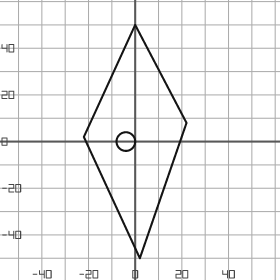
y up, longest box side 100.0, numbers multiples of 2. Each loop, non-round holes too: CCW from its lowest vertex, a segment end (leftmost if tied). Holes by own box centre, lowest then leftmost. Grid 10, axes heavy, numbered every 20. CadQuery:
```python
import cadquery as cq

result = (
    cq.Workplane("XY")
    .moveTo(2.0, -50.0)
    .lineTo(22.0, 8.0)
    .lineTo(0.0, 50.0)
    .lineTo(-22.0, 2.0)
    .close()
    .moveTo(-4.0, 0.0)
    .circle(4.0)
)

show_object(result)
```